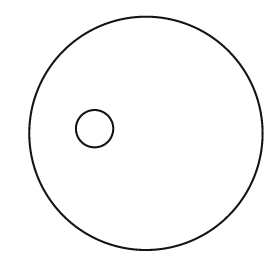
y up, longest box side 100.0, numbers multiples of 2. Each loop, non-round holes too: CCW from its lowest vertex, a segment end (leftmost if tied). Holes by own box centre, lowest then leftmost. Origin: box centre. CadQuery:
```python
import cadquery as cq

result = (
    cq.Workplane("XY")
    .moveTo(0.0, 0.0)
    .circle(50.0)
    .moveTo(-22.0, 2.0)
    .circle(8.0)
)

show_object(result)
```